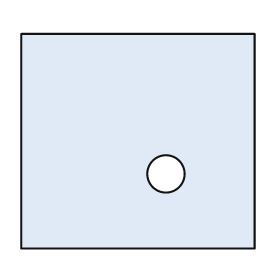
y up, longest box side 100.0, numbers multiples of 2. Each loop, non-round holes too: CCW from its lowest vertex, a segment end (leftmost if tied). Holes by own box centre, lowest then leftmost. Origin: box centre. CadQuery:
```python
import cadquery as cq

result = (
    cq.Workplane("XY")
    .moveTo(-50.0, -46.0)
    .lineTo(50.0, -46.0)
    .lineTo(50.0, 46.0)
    .lineTo(-50.0, 46.0)
    .close()
    .moveTo(12.0, -14.0)
    .circle(8.0)
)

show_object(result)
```